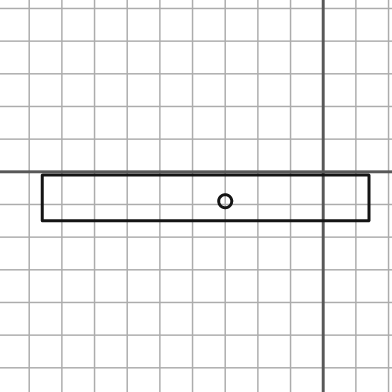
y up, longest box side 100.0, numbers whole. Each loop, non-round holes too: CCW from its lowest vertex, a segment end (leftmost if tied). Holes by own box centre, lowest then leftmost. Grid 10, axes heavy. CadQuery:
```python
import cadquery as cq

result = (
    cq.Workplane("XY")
    .moveTo(-86.0, -15.0)
    .lineTo(14.0, -15.0)
    .lineTo(14.0, -1.0)
    .lineTo(-86.0, -1.0)
    .close()
    .moveTo(-30.0, -9.0)
    .circle(2.0)
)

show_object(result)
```